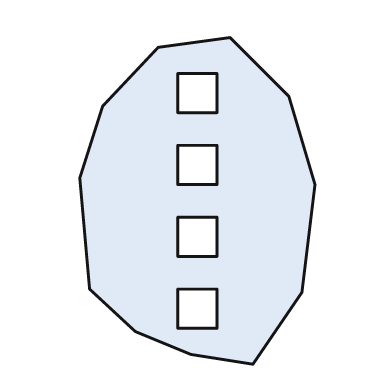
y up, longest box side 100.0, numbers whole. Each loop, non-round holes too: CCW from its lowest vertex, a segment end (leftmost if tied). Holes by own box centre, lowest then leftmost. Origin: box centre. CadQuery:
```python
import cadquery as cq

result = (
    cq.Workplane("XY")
    .moveTo(17.0, -50.0)
    .lineTo(32.0, -28.0)
    .lineTo(36.0, 5.0)
    .lineTo(28.0, 32.0)
    .lineTo(10.0, 50.0)
    .lineTo(-12.0, 47.0)
    .lineTo(-29.0, 29.0)
    .lineTo(-36.0, 7.0)
    .lineTo(-33.0, -27.0)
    .lineTo(-19.0, -40.0)
    .lineTo(-2.0, -47.0)
    .close()
    .moveTo(-6.0, -39.0)
    .lineTo(6.0, -39.0)
    .lineTo(6.0, -27.0)
    .lineTo(-6.0, -27.0)
    .close()
    .moveTo(-6.0, -17.0)
    .lineTo(6.0, -17.0)
    .lineTo(6.0, -5.0)
    .lineTo(-6.0, -5.0)
    .close()
    .moveTo(-6.0, 5.0)
    .lineTo(6.0, 5.0)
    .lineTo(6.0, 17.0)
    .lineTo(-6.0, 17.0)
    .close()
    .moveTo(-6.0, 27.0)
    .lineTo(6.0, 27.0)
    .lineTo(6.0, 39.0)
    .lineTo(-6.0, 39.0)
    .close()
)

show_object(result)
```